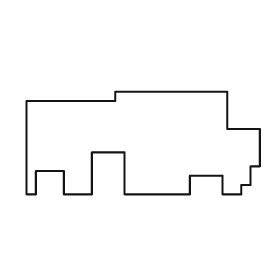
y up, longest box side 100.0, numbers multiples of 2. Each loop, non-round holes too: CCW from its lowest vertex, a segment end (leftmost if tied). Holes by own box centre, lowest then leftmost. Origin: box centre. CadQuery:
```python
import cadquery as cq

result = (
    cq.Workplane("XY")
    .moveTo(-50.0, -22.0)
    .lineTo(-46.0, -22.0)
    .lineTo(-46.0, -12.0)
    .lineTo(-34.0, -12.0)
    .lineTo(-34.0, -22.0)
    .lineTo(-22.0, -22.0)
    .lineTo(-22.0, -4.0)
    .lineTo(-8.0, -4.0)
    .lineTo(-8.0, -22.0)
    .lineTo(20.0, -22.0)
    .lineTo(20.0, -14.0)
    .lineTo(34.0, -14.0)
    .lineTo(34.0, -22.0)
    .lineTo(42.0, -22.0)
    .lineTo(42.0, -18.0)
    .lineTo(46.0, -18.0)
    .lineTo(46.0, -10.0)
    .lineTo(50.0, -10.0)
    .lineTo(50.0, 6.0)
    .lineTo(36.0, 6.0)
    .lineTo(36.0, 22.0)
    .lineTo(-12.0, 22.0)
    .lineTo(-12.0, 18.0)
    .lineTo(-50.0, 18.0)
    .close()
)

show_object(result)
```